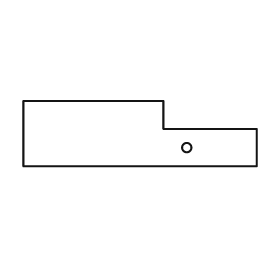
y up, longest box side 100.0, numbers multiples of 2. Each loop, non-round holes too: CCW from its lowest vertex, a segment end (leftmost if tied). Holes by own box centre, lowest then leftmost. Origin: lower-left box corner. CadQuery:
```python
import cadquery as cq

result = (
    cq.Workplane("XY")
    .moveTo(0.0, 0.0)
    .lineTo(100.0, 0.0)
    .lineTo(100.0, 16.0)
    .lineTo(60.0, 16.0)
    .lineTo(60.0, 28.0)
    .lineTo(0.0, 28.0)
    .close()
    .moveTo(70.0, 8.0)
    .circle(2.0)
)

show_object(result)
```